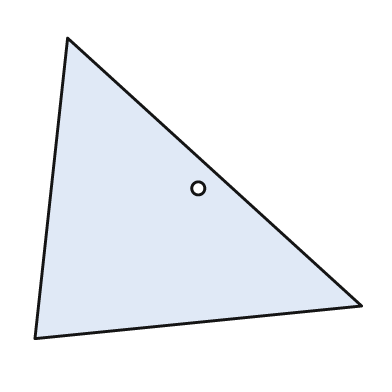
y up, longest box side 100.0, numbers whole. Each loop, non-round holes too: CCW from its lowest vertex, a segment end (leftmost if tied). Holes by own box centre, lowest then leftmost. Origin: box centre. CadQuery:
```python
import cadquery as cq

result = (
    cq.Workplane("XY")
    .moveTo(-50.0, -46.0)
    .lineTo(50.0, -36.0)
    .lineTo(-40.0, 46.0)
    .close()
    .moveTo(0.0, 0.0)
    .circle(2.0)
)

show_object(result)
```